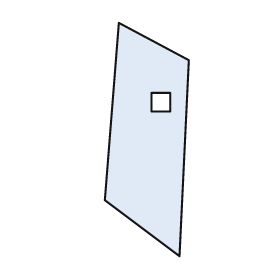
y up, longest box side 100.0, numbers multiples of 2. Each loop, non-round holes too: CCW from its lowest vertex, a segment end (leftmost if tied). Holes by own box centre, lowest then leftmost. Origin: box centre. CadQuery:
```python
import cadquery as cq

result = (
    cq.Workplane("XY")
    .moveTo(14.0, -50.0)
    .lineTo(18.0, 34.0)
    .lineTo(-12.0, 50.0)
    .lineTo(-18.0, -26.0)
    .close()
    .moveTo(2.0, 12.0)
    .lineTo(10.0, 12.0)
    .lineTo(10.0, 20.0)
    .lineTo(2.0, 20.0)
    .close()
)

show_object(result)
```